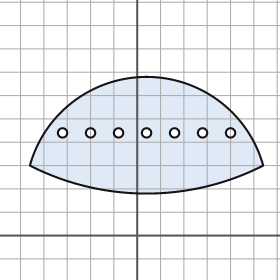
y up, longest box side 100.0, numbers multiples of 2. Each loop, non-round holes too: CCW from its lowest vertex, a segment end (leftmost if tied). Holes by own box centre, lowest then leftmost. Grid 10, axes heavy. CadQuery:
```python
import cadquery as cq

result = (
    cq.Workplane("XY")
    .moveTo(-46.0, 30.0)
    .threePointArc((4.0, 18.0), (54.0, 30.0))
    .threePointArc((4.0, 68.0), (-46.0, 30.0))
    .close()
    .moveTo(-32.0, 44.0)
    .circle(2.0)
    .moveTo(-20.0, 44.0)
    .circle(2.0)
    .moveTo(-8.0, 44.0)
    .circle(2.0)
    .moveTo(4.0, 44.0)
    .circle(2.0)
    .moveTo(16.0, 44.0)
    .circle(2.0)
    .moveTo(28.0, 44.0)
    .circle(2.0)
    .moveTo(40.0, 44.0)
    .circle(2.0)
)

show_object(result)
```